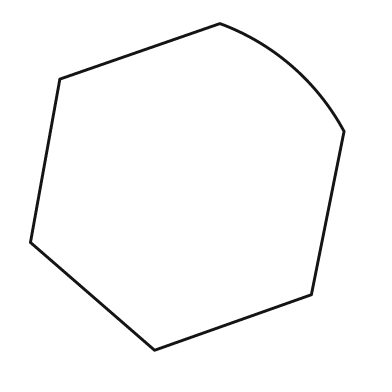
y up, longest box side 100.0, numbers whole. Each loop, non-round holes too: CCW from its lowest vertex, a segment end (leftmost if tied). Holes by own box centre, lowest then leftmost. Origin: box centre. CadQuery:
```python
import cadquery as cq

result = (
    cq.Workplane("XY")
    .moveTo(-10.0, -50.0)
    .lineTo(38.0, -33.0)
    .lineTo(48.0, 17.0)
    .threePointArc((32.0, 37.0), (10.0, 50.0))
    .lineTo(-39.0, 33.0)
    .lineTo(-48.0, -17.0)
    .close()
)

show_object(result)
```